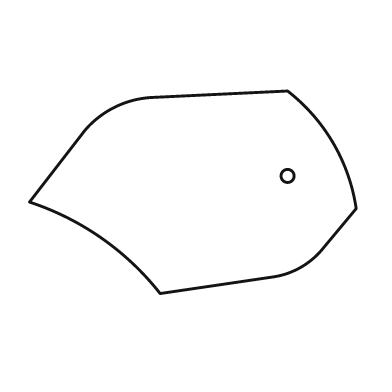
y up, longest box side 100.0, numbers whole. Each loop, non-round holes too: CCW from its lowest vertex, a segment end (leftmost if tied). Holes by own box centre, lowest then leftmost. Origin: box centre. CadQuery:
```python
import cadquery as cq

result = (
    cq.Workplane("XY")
    .moveTo(-10.0, -31.0)
    .lineTo(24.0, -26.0)
    .threePointArc((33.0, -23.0), (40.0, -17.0))
    .lineTo(50.0, -5.0)
    .threePointArc((43.0, 15.0), (29.0, 31.0))
    .lineTo(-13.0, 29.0)
    .threePointArc((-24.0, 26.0), (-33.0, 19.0))
    .lineTo(-50.0, -3.0)
    .threePointArc((-28.0, -14.0), (-10.0, -31.0))
    .close()
    .moveTo(29.0, 5.0)
    .circle(2.0)
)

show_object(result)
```